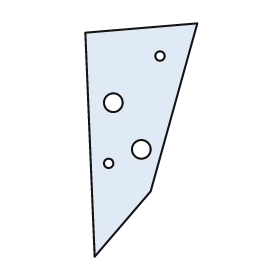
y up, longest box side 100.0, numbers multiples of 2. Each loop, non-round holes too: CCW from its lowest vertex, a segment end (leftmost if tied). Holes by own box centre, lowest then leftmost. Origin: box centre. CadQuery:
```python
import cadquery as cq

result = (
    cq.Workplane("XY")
    .moveTo(-20.0, -50.0)
    .lineTo(4.0, -22.0)
    .lineTo(24.0, 50.0)
    .lineTo(-24.0, 46.0)
    .close()
    .moveTo(-14.0, -10.0)
    .circle(2.0)
    .moveTo(0.0, -4.0)
    .circle(4.0)
    .moveTo(-12.0, 16.0)
    .circle(4.0)
    .moveTo(8.0, 36.0)
    .circle(2.0)
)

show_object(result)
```